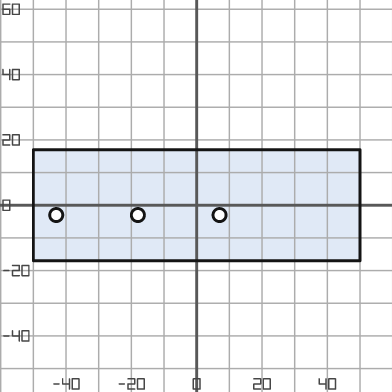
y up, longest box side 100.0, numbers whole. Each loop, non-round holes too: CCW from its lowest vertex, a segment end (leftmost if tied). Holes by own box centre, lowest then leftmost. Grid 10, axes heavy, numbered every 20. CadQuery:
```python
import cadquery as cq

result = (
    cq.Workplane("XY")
    .moveTo(-50.0, -17.0)
    .lineTo(50.0, -17.0)
    .lineTo(50.0, 17.0)
    .lineTo(-50.0, 17.0)
    .close()
    .moveTo(-43.0, -3.0)
    .circle(2.0)
    .moveTo(-18.0, -3.0)
    .circle(2.0)
    .moveTo(7.0, -3.0)
    .circle(2.0)
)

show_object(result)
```